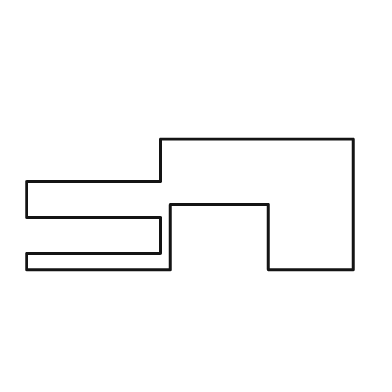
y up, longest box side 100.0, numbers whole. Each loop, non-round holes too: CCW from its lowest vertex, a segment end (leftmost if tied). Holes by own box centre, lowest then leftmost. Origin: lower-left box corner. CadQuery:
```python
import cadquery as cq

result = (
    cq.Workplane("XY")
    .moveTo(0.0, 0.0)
    .lineTo(44.0, 0.0)
    .lineTo(44.0, 20.0)
    .lineTo(74.0, 20.0)
    .lineTo(74.0, 0.0)
    .lineTo(100.0, 0.0)
    .lineTo(100.0, 40.0)
    .lineTo(41.0, 40.0)
    .lineTo(41.0, 27.0)
    .lineTo(0.0, 27.0)
    .lineTo(0.0, 16.0)
    .lineTo(41.0, 16.0)
    .lineTo(41.0, 5.0)
    .lineTo(0.0, 5.0)
    .close()
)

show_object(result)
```